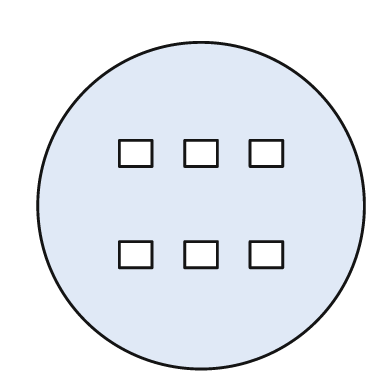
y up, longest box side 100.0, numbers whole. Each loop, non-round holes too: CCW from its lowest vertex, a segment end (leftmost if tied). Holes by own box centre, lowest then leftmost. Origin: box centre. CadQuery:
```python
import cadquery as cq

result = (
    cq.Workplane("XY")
    .moveTo(0.0, 0.0)
    .circle(50.0)
    .moveTo(-25.0, -19.0)
    .lineTo(-15.0, -19.0)
    .lineTo(-15.0, -11.0)
    .lineTo(-25.0, -11.0)
    .close()
    .moveTo(-5.0, -19.0)
    .lineTo(5.0, -19.0)
    .lineTo(5.0, -11.0)
    .lineTo(-5.0, -11.0)
    .close()
    .moveTo(15.0, -19.0)
    .lineTo(25.0, -19.0)
    .lineTo(25.0, -11.0)
    .lineTo(15.0, -11.0)
    .close()
    .moveTo(-25.0, 12.0)
    .lineTo(-15.0, 12.0)
    .lineTo(-15.0, 20.0)
    .lineTo(-25.0, 20.0)
    .close()
    .moveTo(-5.0, 12.0)
    .lineTo(5.0, 12.0)
    .lineTo(5.0, 20.0)
    .lineTo(-5.0, 20.0)
    .close()
    .moveTo(15.0, 12.0)
    .lineTo(25.0, 12.0)
    .lineTo(25.0, 20.0)
    .lineTo(15.0, 20.0)
    .close()
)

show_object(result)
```